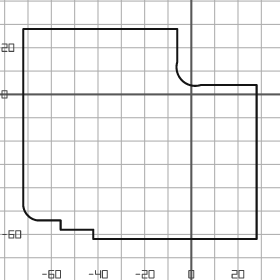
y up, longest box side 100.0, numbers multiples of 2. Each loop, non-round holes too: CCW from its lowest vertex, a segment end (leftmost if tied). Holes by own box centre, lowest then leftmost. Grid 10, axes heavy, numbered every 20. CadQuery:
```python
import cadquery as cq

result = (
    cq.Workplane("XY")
    .moveTo(-42.0, -62.0)
    .lineTo(28.0, -62.0)
    .lineTo(28.0, 4.0)
    .lineTo(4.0, 4.0)
    .threePointArc((-4.0, 6.0), (-6.0, 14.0))
    .lineTo(-6.0, 28.0)
    .lineTo(-72.0, 28.0)
    .lineTo(-72.0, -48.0)
    .threePointArc((-70.0, -52.0), (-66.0, -54.0))
    .lineTo(-56.0, -54.0)
    .lineTo(-56.0, -58.0)
    .lineTo(-42.0, -58.0)
    .close()
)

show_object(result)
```